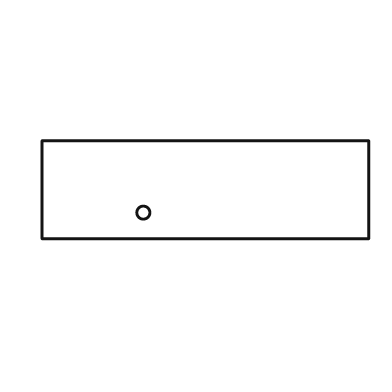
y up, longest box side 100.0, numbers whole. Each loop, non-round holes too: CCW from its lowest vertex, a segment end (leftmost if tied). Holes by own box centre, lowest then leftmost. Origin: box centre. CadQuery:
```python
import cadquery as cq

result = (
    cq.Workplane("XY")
    .moveTo(-50.0, -15.0)
    .lineTo(50.0, -15.0)
    .lineTo(50.0, 15.0)
    .lineTo(-50.0, 15.0)
    .close()
    .moveTo(-19.0, -7.0)
    .circle(2.0)
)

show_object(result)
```